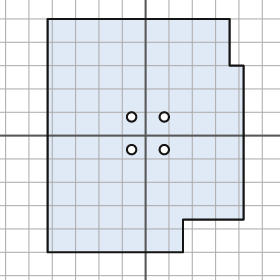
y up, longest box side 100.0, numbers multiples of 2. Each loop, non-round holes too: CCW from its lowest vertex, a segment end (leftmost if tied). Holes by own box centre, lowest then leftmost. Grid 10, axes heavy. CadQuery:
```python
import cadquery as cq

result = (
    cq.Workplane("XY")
    .moveTo(-42.0, -50.0)
    .lineTo(16.0, -50.0)
    .lineTo(16.0, -36.0)
    .lineTo(42.0, -36.0)
    .lineTo(42.0, 30.0)
    .lineTo(36.0, 30.0)
    .lineTo(36.0, 50.0)
    .lineTo(-42.0, 50.0)
    .close()
    .moveTo(-6.0, -6.0)
    .circle(2.0)
    .moveTo(8.0, -6.0)
    .circle(2.0)
    .moveTo(-6.0, 8.0)
    .circle(2.0)
    .moveTo(8.0, 8.0)
    .circle(2.0)
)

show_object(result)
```